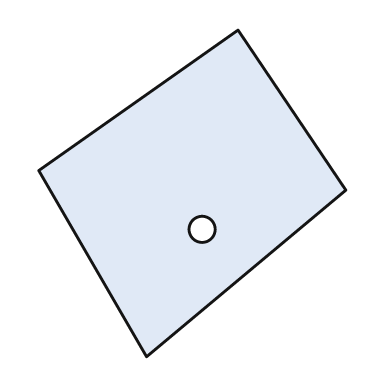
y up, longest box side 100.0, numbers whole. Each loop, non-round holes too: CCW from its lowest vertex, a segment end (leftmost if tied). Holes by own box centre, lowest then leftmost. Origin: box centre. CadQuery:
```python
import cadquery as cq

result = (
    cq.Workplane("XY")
    .moveTo(-14.0, -50.0)
    .lineTo(47.0, 1.0)
    .lineTo(14.0, 50.0)
    .lineTo(-47.0, 7.0)
    .close()
    .moveTo(3.0, -11.0)
    .circle(4.0)
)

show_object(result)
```